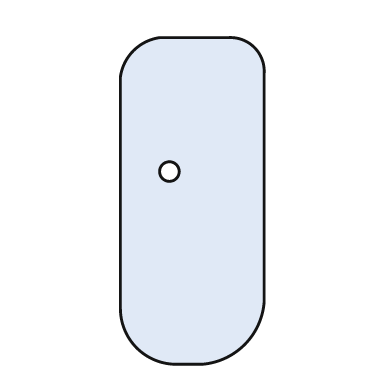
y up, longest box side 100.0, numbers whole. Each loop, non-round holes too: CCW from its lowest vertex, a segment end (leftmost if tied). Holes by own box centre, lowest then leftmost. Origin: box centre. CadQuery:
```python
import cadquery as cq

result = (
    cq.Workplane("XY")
    .moveTo(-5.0, -50.0)
    .lineTo(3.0, -50.0)
    .threePointArc((16.0, -44.0), (22.0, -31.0))
    .lineTo(22.0, 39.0)
    .threePointArc((19.0, 47.0), (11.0, 50.0))
    .lineTo(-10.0, 50.0)
    .threePointArc((-18.0, 46.0), (-22.0, 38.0))
    .lineTo(-22.0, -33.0)
    .threePointArc((-17.0, -45.0), (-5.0, -50.0))
    .close()
    .moveTo(-7.0, 9.0)
    .circle(3.0)
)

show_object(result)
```